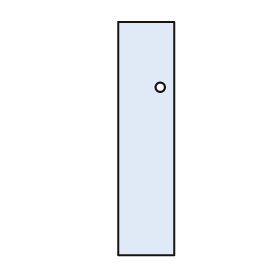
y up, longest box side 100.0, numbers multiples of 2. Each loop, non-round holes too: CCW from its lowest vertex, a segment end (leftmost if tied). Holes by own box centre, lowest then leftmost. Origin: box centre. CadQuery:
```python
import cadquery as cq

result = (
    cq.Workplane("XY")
    .moveTo(-12.0, -50.0)
    .lineTo(12.0, -50.0)
    .lineTo(12.0, 50.0)
    .lineTo(-12.0, 50.0)
    .close()
    .moveTo(6.0, 22.0)
    .circle(2.0)
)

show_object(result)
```